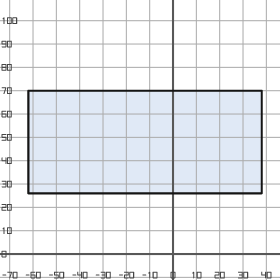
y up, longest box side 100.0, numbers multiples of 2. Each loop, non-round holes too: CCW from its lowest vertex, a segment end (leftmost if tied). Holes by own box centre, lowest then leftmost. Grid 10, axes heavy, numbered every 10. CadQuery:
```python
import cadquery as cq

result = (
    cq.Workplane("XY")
    .moveTo(-62.0, 26.0)
    .lineTo(38.0, 26.0)
    .lineTo(38.0, 70.0)
    .lineTo(-62.0, 70.0)
    .close()
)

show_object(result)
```